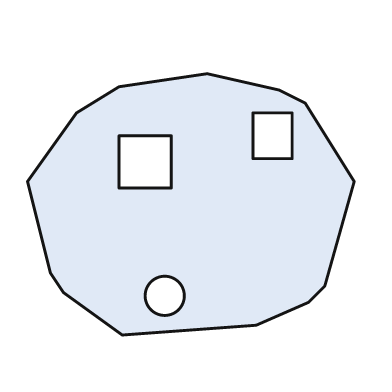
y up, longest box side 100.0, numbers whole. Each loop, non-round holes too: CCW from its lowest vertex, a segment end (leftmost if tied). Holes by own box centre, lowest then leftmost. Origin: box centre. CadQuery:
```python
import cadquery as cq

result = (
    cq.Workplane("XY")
    .moveTo(-21.0, -40.0)
    .lineTo(20.0, -37.0)
    .lineTo(36.0, -30.0)
    .lineTo(41.0, -25.0)
    .lineTo(50.0, 7.0)
    .lineTo(35.0, 31.0)
    .lineTo(27.0, 35.0)
    .lineTo(5.0, 40.0)
    .lineTo(-22.0, 36.0)
    .lineTo(-35.0, 28.0)
    .lineTo(-50.0, 7.0)
    .lineTo(-43.0, -21.0)
    .lineTo(-39.0, -27.0)
    .close()
    .moveTo(-8.0, -28.0)
    .circle(6.0)
    .moveTo(-22.0, 5.0)
    .lineTo(-6.0, 5.0)
    .lineTo(-6.0, 21.0)
    .lineTo(-22.0, 21.0)
    .close()
    .moveTo(19.0, 14.0)
    .lineTo(31.0, 14.0)
    .lineTo(31.0, 28.0)
    .lineTo(19.0, 28.0)
    .close()
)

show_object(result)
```